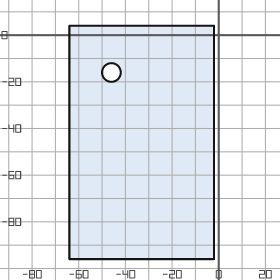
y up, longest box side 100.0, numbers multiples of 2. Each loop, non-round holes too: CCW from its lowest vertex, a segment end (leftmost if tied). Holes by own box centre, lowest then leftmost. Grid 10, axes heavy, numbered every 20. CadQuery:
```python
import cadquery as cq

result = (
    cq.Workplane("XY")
    .moveTo(-64.0, -96.0)
    .lineTo(-2.0, -96.0)
    .lineTo(-2.0, 4.0)
    .lineTo(-64.0, 4.0)
    .close()
    .moveTo(-46.0, -16.0)
    .circle(4.0)
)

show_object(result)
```